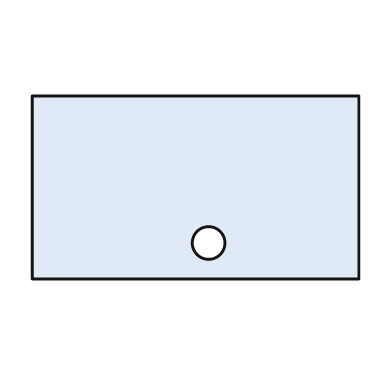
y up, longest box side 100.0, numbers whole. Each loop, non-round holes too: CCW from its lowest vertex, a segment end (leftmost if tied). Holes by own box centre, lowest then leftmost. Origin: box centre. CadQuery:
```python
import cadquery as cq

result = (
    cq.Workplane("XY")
    .moveTo(-50.0, -28.0)
    .lineTo(50.0, -28.0)
    .lineTo(50.0, 28.0)
    .lineTo(-50.0, 28.0)
    .close()
    .moveTo(4.0, -17.0)
    .circle(5.0)
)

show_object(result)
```